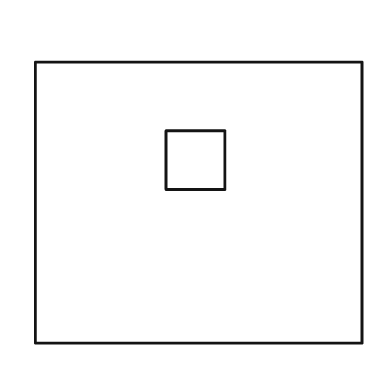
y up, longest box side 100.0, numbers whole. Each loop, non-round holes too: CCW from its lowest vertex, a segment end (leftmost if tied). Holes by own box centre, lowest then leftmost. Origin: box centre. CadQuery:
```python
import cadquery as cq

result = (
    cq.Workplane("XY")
    .moveTo(-50.0, -43.0)
    .lineTo(50.0, -43.0)
    .lineTo(50.0, 43.0)
    .lineTo(-50.0, 43.0)
    .close()
    .moveTo(-10.0, 4.0)
    .lineTo(8.0, 4.0)
    .lineTo(8.0, 22.0)
    .lineTo(-10.0, 22.0)
    .close()
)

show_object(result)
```